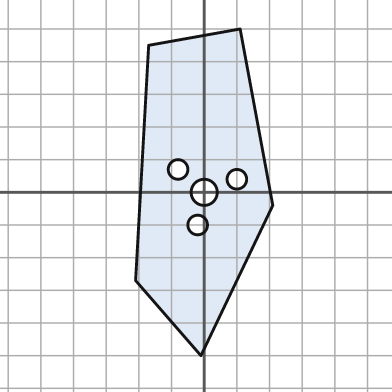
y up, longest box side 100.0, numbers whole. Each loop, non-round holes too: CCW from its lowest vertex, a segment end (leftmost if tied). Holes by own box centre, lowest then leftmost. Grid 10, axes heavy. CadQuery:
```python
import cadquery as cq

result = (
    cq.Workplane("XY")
    .moveTo(-1.0, -50.0)
    .lineTo(21.0, -4.0)
    .lineTo(11.0, 50.0)
    .lineTo(-17.0, 45.0)
    .lineTo(-21.0, -27.0)
    .close()
    .moveTo(-2.0, -10.0)
    .circle(3.0)
    .moveTo(0.0, 0.0)
    .circle(4.0)
    .moveTo(10.0, 4.0)
    .circle(3.0)
    .moveTo(-8.0, 7.0)
    .circle(3.0)
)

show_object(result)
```